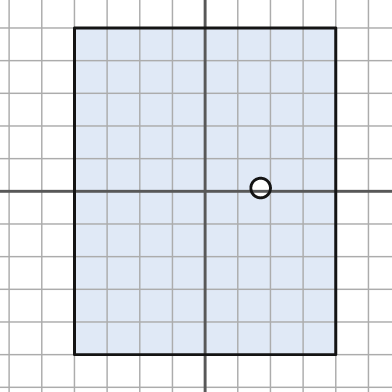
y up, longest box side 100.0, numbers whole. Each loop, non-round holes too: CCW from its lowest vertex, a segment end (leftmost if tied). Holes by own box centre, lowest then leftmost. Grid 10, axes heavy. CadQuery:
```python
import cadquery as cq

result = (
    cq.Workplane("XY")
    .moveTo(-40.0, -50.0)
    .lineTo(40.0, -50.0)
    .lineTo(40.0, 50.0)
    .lineTo(-40.0, 50.0)
    .close()
    .moveTo(17.0, 1.0)
    .circle(3.0)
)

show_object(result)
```